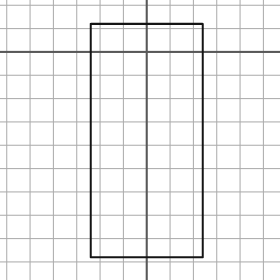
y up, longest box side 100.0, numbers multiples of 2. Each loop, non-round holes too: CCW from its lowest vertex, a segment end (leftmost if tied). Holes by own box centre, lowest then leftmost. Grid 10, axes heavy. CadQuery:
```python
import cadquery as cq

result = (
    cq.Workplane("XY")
    .moveTo(-24.0, -88.0)
    .lineTo(24.0, -88.0)
    .lineTo(24.0, 12.0)
    .lineTo(-24.0, 12.0)
    .close()
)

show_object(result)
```